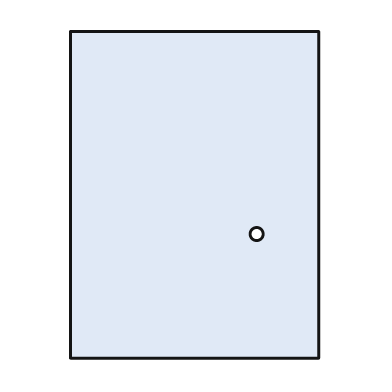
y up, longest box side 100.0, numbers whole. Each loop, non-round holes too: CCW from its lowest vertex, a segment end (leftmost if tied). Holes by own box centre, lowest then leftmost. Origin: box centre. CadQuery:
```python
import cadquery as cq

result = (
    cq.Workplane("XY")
    .moveTo(-38.0, -50.0)
    .lineTo(38.0, -50.0)
    .lineTo(38.0, 50.0)
    .lineTo(-38.0, 50.0)
    .close()
    .moveTo(19.0, -12.0)
    .circle(2.0)
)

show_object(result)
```